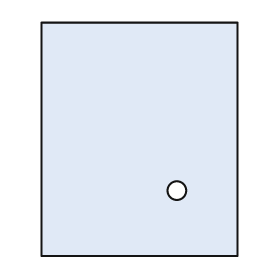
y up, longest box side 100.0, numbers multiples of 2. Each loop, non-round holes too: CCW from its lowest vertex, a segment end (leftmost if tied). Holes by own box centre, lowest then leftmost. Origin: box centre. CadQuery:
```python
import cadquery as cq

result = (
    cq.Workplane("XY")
    .moveTo(-42.0, -50.0)
    .lineTo(42.0, -50.0)
    .lineTo(42.0, 50.0)
    .lineTo(-42.0, 50.0)
    .close()
    .moveTo(16.0, -22.0)
    .circle(4.0)
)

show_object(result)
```